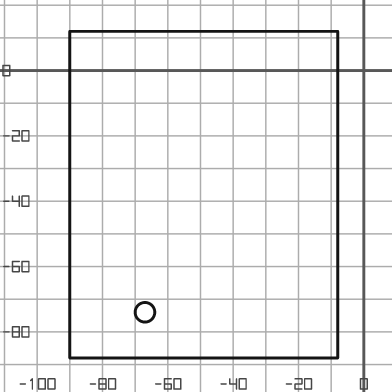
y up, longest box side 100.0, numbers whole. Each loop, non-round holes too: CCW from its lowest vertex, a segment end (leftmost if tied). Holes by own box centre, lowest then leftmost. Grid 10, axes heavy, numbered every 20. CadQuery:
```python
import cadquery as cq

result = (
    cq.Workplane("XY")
    .moveTo(-90.0, -88.0)
    .lineTo(-8.0, -88.0)
    .lineTo(-8.0, 12.0)
    .lineTo(-90.0, 12.0)
    .close()
    .moveTo(-67.0, -74.0)
    .circle(3.0)
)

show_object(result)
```